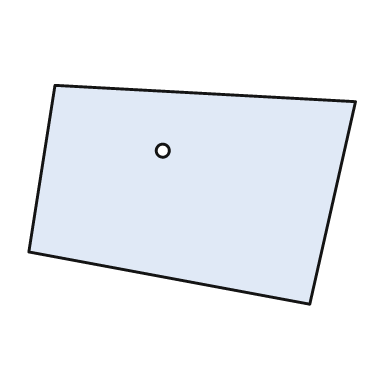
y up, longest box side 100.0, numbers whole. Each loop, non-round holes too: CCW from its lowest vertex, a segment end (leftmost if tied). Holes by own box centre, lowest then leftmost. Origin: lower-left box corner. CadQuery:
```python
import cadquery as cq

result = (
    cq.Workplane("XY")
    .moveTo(86.0, 0.0)
    .lineTo(100.0, 62.0)
    .lineTo(8.0, 67.0)
    .lineTo(0.0, 16.0)
    .close()
    .moveTo(41.0, 47.0)
    .circle(2.0)
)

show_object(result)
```